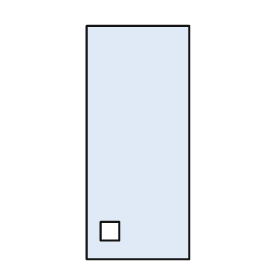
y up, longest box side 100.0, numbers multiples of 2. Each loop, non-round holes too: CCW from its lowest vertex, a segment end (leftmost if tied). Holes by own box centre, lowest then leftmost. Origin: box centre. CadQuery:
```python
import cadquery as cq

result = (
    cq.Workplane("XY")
    .moveTo(-22.0, -50.0)
    .lineTo(22.0, -50.0)
    .lineTo(22.0, 50.0)
    .lineTo(-22.0, 50.0)
    .close()
    .moveTo(-16.0, -42.0)
    .lineTo(-8.0, -42.0)
    .lineTo(-8.0, -34.0)
    .lineTo(-16.0, -34.0)
    .close()
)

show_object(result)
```